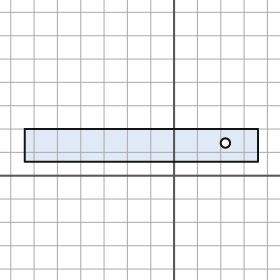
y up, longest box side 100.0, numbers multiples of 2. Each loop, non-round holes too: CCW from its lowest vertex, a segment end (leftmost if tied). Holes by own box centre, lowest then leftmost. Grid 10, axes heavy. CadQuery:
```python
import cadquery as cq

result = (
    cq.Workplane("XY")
    .moveTo(-64.0, 6.0)
    .lineTo(36.0, 6.0)
    .lineTo(36.0, 20.0)
    .lineTo(-64.0, 20.0)
    .close()
    .moveTo(22.0, 14.0)
    .circle(2.0)
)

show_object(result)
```